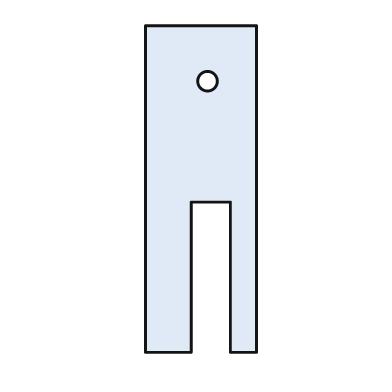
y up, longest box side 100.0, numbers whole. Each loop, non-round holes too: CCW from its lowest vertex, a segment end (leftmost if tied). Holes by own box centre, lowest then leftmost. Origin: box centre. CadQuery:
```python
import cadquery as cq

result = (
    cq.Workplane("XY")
    .moveTo(-17.0, -50.0)
    .lineTo(-3.0, -50.0)
    .lineTo(-3.0, -4.0)
    .lineTo(9.0, -4.0)
    .lineTo(9.0, -50.0)
    .lineTo(17.0, -50.0)
    .lineTo(17.0, 50.0)
    .lineTo(-17.0, 50.0)
    .close()
    .moveTo(2.0, 33.0)
    .circle(3.0)
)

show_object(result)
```